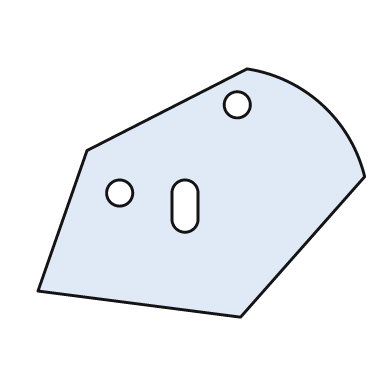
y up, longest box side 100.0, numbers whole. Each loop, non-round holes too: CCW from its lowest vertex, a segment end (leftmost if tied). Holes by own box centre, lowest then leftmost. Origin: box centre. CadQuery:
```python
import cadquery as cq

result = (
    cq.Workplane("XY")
    .moveTo(12.0, -38.0)
    .lineTo(50.0, 5.0)
    .threePointArc((37.0, 27.0), (14.0, 38.0))
    .lineTo(-35.0, 13.0)
    .lineTo(-50.0, -30.0)
    .close()
    .moveTo(-9.0, -8.0)
    .threePointArc((-5.0, -12.0), (-1.0, -8.0))
    .lineTo(-1.0, 0.0)
    .threePointArc((-5.0, 4.0), (-9.0, 0.0))
    .close()
    .moveTo(-25.0, 0.0)
    .circle(4.0)
    .moveTo(11.0, 27.0)
    .circle(4.0)
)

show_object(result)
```